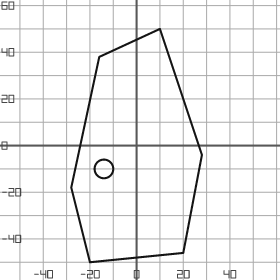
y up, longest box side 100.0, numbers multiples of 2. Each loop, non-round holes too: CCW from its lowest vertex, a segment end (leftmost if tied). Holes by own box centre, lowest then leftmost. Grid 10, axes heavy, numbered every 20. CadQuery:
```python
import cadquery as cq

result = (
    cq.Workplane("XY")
    .moveTo(-20.0, -50.0)
    .lineTo(20.0, -46.0)
    .lineTo(28.0, -4.0)
    .lineTo(10.0, 50.0)
    .lineTo(-16.0, 38.0)
    .lineTo(-28.0, -18.0)
    .close()
    .moveTo(-14.0, -10.0)
    .circle(4.0)
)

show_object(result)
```